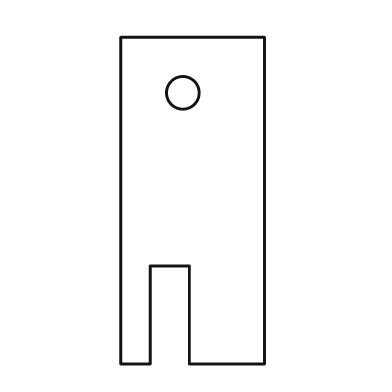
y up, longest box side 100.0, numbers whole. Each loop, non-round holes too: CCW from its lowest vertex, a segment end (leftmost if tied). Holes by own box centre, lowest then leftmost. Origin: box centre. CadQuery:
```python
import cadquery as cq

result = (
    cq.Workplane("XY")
    .moveTo(-22.0, -50.0)
    .lineTo(-13.0, -50.0)
    .lineTo(-13.0, -20.0)
    .lineTo(-1.0, -20.0)
    .lineTo(-1.0, -50.0)
    .lineTo(22.0, -50.0)
    .lineTo(22.0, 50.0)
    .lineTo(-22.0, 50.0)
    .close()
    .moveTo(-3.0, 33.0)
    .circle(5.0)
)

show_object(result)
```